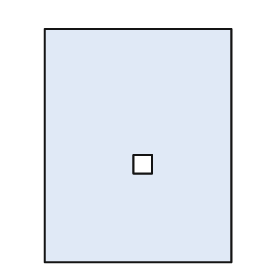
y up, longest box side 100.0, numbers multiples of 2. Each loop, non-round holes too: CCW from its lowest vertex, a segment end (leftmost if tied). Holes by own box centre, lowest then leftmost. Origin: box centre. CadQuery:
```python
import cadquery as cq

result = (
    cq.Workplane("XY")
    .moveTo(-40.0, -50.0)
    .lineTo(40.0, -50.0)
    .lineTo(40.0, 50.0)
    .lineTo(-40.0, 50.0)
    .close()
    .moveTo(-2.0, -12.0)
    .lineTo(6.0, -12.0)
    .lineTo(6.0, -4.0)
    .lineTo(-2.0, -4.0)
    .close()
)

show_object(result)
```